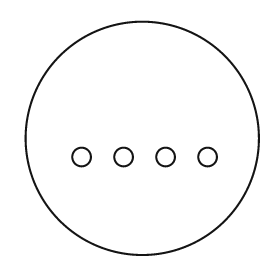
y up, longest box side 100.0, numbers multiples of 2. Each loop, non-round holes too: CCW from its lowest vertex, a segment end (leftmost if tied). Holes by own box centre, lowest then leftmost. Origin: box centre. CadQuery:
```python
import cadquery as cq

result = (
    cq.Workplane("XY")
    .moveTo(0.0, 0.0)
    .circle(50.0)
    .moveTo(-26.0, -8.0)
    .circle(4.0)
    .moveTo(-8.0, -8.0)
    .circle(4.0)
    .moveTo(10.0, -8.0)
    .circle(4.0)
    .moveTo(28.0, -8.0)
    .circle(4.0)
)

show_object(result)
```